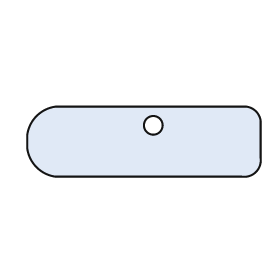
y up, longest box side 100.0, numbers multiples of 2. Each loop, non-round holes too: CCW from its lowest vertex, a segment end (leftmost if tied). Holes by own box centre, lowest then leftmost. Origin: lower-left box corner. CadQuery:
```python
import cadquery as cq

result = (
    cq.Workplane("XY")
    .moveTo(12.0, 0.0)
    .lineTo(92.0, 0.0)
    .threePointArc((98.0, 2.0), (100.0, 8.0))
    .lineTo(100.0, 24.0)
    .threePointArc((98.0, 28.0), (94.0, 30.0))
    .lineTo(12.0, 30.0)
    .threePointArc((4.0, 26.0), (0.0, 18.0))
    .lineTo(0.0, 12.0)
    .threePointArc((4.0, 4.0), (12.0, 0.0))
    .close()
    .moveTo(54.0, 22.0)
    .circle(4.0)
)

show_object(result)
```